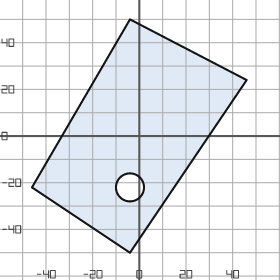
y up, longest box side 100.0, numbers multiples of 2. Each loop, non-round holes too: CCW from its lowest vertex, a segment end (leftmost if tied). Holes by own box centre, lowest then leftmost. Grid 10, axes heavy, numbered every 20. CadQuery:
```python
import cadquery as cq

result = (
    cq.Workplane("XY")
    .moveTo(-4.0, -50.0)
    .lineTo(46.0, 24.0)
    .lineTo(-4.0, 50.0)
    .lineTo(-46.0, -22.0)
    .close()
    .moveTo(-4.0, -22.0)
    .circle(6.0)
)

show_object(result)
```